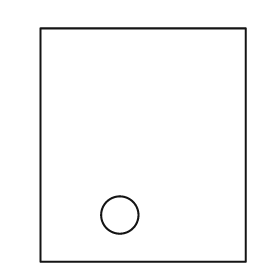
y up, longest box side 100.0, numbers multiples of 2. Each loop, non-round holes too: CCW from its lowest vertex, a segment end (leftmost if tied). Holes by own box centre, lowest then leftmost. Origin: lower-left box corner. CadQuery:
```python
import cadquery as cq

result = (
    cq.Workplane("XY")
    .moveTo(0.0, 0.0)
    .lineTo(88.0, 0.0)
    .lineTo(88.0, 100.0)
    .lineTo(0.0, 100.0)
    .close()
    .moveTo(34.0, 20.0)
    .circle(8.0)
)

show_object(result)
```